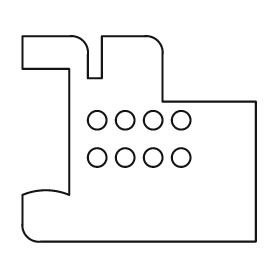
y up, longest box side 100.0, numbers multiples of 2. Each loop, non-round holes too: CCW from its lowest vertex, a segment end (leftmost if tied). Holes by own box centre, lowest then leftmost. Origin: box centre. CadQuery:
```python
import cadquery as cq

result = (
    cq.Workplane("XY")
    .moveTo(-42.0, -44.0)
    .lineTo(50.0, -44.0)
    .lineTo(50.0, 16.0)
    .lineTo(10.0, 16.0)
    .lineTo(10.0, 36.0)
    .threePointArc((8.0, 42.0), (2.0, 44.0))
    .lineTo(-16.0, 44.0)
    .lineTo(-16.0, 26.0)
    .lineTo(-22.0, 26.0)
    .lineTo(-22.0, 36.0)
    .threePointArc((-24.0, 42.0), (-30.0, 44.0))
    .lineTo(-50.0, 44.0)
    .lineTo(-50.0, 30.0)
    .lineTo(-30.0, 30.0)
    .lineTo(-30.0, -24.0)
    .threePointArc((-40.0, -22.0), (-50.0, -24.0))
    .lineTo(-50.0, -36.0)
    .threePointArc((-48.0, -42.0), (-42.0, -44.0))
    .close()
    .moveTo(-18.0, -8.0)
    .circle(4.0)
    .moveTo(-6.0, -8.0)
    .circle(4.0)
    .moveTo(6.0, -8.0)
    .circle(4.0)
    .moveTo(18.0, -8.0)
    .circle(4.0)
    .moveTo(-18.0, 8.0)
    .circle(4.0)
    .moveTo(-6.0, 8.0)
    .circle(4.0)
    .moveTo(6.0, 8.0)
    .circle(4.0)
    .moveTo(18.0, 8.0)
    .circle(4.0)
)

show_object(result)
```